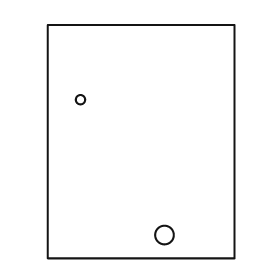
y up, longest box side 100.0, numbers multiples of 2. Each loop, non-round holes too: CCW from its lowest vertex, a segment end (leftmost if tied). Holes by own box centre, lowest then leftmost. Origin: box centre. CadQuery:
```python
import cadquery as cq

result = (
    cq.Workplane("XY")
    .moveTo(-40.0, -50.0)
    .lineTo(40.0, -50.0)
    .lineTo(40.0, 50.0)
    .lineTo(-40.0, 50.0)
    .close()
    .moveTo(10.0, -40.0)
    .circle(4.0)
    .moveTo(-26.0, 18.0)
    .circle(2.0)
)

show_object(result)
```